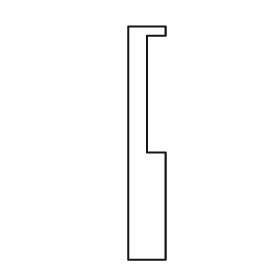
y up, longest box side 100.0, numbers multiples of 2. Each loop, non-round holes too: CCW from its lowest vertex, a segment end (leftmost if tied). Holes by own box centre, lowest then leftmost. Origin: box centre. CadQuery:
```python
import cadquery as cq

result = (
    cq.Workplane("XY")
    .moveTo(-8.0, -50.0)
    .lineTo(8.0, -50.0)
    .lineTo(8.0, -4.0)
    .lineTo(0.0, -4.0)
    .lineTo(0.0, 46.0)
    .lineTo(8.0, 46.0)
    .lineTo(8.0, 50.0)
    .lineTo(-8.0, 50.0)
    .close()
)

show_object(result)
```